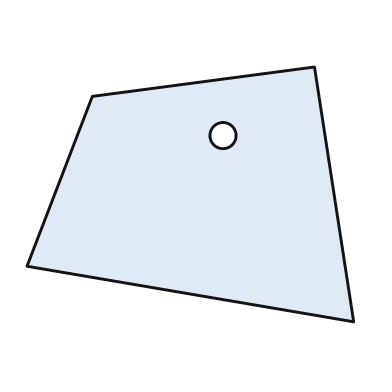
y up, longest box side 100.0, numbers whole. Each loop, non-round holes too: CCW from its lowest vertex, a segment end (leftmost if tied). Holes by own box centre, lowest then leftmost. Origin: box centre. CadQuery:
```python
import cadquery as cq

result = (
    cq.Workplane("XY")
    .moveTo(50.0, -39.0)
    .lineTo(38.0, 39.0)
    .lineTo(-30.0, 30.0)
    .lineTo(-50.0, -22.0)
    .close()
    .moveTo(10.0, 18.0)
    .circle(4.0)
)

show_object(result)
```